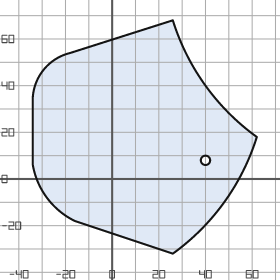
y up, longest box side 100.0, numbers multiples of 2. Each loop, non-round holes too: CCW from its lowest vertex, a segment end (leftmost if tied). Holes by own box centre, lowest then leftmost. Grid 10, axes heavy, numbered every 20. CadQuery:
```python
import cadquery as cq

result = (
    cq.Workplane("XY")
    .moveTo(26.0, -32.0)
    .threePointArc((48.0, -10.0), (62.0, 18.0))
    .threePointArc((40.0, 40.0), (26.0, 68.0))
    .lineTo(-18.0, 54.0)
    .threePointArc((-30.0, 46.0), (-34.0, 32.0))
    .lineTo(-34.0, 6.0)
    .threePointArc((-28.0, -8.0), (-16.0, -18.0))
    .close()
    .moveTo(40.0, 8.0)
    .circle(2.0)
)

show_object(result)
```